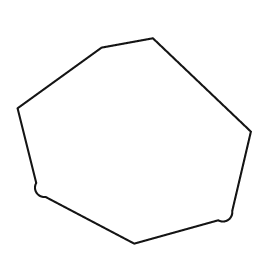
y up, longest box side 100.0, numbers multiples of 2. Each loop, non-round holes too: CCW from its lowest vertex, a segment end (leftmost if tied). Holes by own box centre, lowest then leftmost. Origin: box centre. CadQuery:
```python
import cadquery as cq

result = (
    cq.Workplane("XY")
    .moveTo(0.0, -44.0)
    .lineTo(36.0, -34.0)
    .threePointArc((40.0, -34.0), (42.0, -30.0))
    .lineTo(50.0, 4.0)
    .lineTo(8.0, 44.0)
    .lineTo(-14.0, 40.0)
    .lineTo(-50.0, 14.0)
    .lineTo(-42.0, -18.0)
    .threePointArc((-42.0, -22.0), (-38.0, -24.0))
    .close()
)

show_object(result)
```